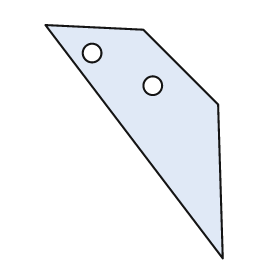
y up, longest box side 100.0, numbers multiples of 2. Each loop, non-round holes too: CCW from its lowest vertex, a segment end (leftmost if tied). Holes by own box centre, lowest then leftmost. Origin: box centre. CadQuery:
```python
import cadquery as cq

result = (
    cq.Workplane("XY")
    .moveTo(38.0, -50.0)
    .lineTo(36.0, 16.0)
    .lineTo(4.0, 48.0)
    .lineTo(-38.0, 50.0)
    .close()
    .moveTo(8.0, 24.0)
    .circle(4.0)
    .moveTo(-18.0, 38.0)
    .circle(4.0)
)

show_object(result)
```